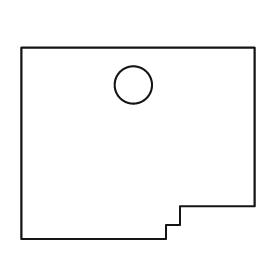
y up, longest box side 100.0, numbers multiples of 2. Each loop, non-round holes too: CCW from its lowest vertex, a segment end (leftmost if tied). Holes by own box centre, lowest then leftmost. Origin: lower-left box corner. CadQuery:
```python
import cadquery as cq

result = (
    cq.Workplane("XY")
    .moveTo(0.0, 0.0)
    .lineTo(62.0, 0.0)
    .lineTo(62.0, 6.0)
    .lineTo(68.0, 6.0)
    .lineTo(68.0, 14.0)
    .lineTo(100.0, 14.0)
    .lineTo(100.0, 82.0)
    .lineTo(0.0, 82.0)
    .close()
    .moveTo(48.0, 66.0)
    .circle(8.0)
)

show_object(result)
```